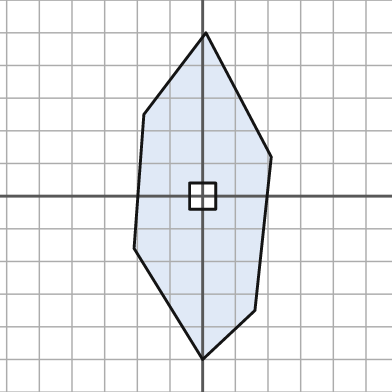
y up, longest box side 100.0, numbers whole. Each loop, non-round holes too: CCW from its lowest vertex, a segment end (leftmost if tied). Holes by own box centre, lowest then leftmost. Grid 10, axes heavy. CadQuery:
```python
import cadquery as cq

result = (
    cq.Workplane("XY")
    .moveTo(0.0, -50.0)
    .lineTo(16.0, -35.0)
    .lineTo(21.0, 12.0)
    .lineTo(1.0, 50.0)
    .lineTo(-18.0, 25.0)
    .lineTo(-21.0, -16.0)
    .close()
    .moveTo(-4.0, -4.0)
    .lineTo(4.0, -4.0)
    .lineTo(4.0, 4.0)
    .lineTo(-4.0, 4.0)
    .close()
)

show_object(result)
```